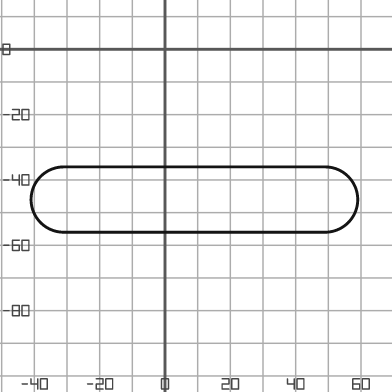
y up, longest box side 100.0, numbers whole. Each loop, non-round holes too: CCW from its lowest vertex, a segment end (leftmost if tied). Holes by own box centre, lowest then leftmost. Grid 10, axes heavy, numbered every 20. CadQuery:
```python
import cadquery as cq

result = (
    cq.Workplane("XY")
    .moveTo(-31.0, -56.0)
    .lineTo(49.0, -56.0)
    .threePointArc((59.0, -46.0), (49.0, -36.0))
    .lineTo(-31.0, -36.0)
    .threePointArc((-41.0, -46.0), (-31.0, -56.0))
    .close()
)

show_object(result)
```